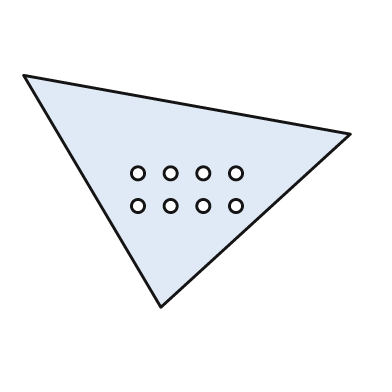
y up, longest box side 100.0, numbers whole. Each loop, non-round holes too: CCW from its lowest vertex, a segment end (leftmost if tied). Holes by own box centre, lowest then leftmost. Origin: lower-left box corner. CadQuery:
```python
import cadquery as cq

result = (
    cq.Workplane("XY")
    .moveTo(42.0, 0.0)
    .lineTo(100.0, 53.0)
    .lineTo(0.0, 71.0)
    .close()
    .moveTo(35.0, 31.0)
    .circle(2.0)
    .moveTo(45.0, 31.0)
    .circle(2.0)
    .moveTo(55.0, 31.0)
    .circle(2.0)
    .moveTo(65.0, 31.0)
    .circle(2.0)
    .moveTo(35.0, 41.0)
    .circle(2.0)
    .moveTo(45.0, 41.0)
    .circle(2.0)
    .moveTo(55.0, 41.0)
    .circle(2.0)
    .moveTo(65.0, 41.0)
    .circle(2.0)
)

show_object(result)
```